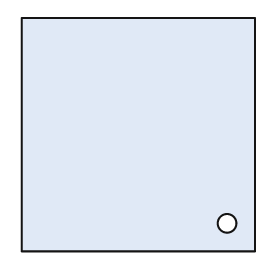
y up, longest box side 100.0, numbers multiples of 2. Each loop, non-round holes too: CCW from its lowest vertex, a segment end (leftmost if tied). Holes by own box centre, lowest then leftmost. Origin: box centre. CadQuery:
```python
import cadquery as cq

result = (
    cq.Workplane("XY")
    .moveTo(-50.0, -50.0)
    .lineTo(50.0, -50.0)
    .lineTo(50.0, 50.0)
    .lineTo(-50.0, 50.0)
    .close()
    .moveTo(38.0, -38.0)
    .circle(4.0)
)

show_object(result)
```